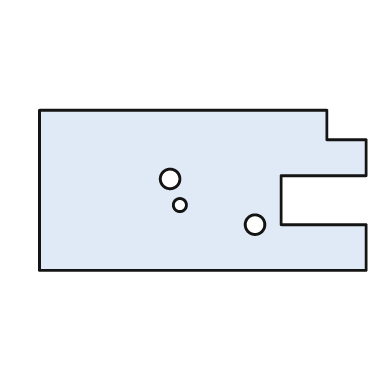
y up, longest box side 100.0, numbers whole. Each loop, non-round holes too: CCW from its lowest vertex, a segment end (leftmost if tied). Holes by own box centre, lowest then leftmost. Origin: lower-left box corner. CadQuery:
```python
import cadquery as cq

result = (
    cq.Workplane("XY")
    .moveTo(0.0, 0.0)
    .lineTo(100.0, 0.0)
    .lineTo(100.0, 14.0)
    .lineTo(74.0, 14.0)
    .lineTo(74.0, 29.0)
    .lineTo(100.0, 29.0)
    .lineTo(100.0, 40.0)
    .lineTo(88.0, 40.0)
    .lineTo(88.0, 49.0)
    .lineTo(0.0, 49.0)
    .close()
    .moveTo(66.0, 14.0)
    .circle(3.0)
    .moveTo(43.0, 20.0)
    .circle(2.0)
    .moveTo(40.0, 28.0)
    .circle(3.0)
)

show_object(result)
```